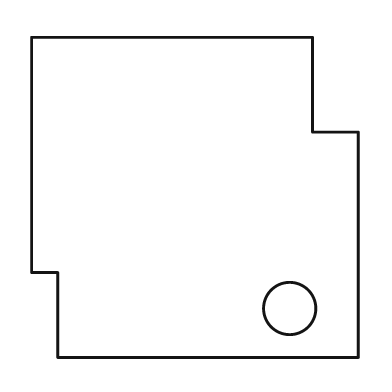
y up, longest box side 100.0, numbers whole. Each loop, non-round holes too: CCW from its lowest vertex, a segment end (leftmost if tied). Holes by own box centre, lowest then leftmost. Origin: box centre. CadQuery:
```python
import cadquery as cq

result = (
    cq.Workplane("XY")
    .moveTo(-42.0, -49.0)
    .lineTo(50.0, -49.0)
    .lineTo(50.0, 20.0)
    .lineTo(36.0, 20.0)
    .lineTo(36.0, 49.0)
    .lineTo(-50.0, 49.0)
    .lineTo(-50.0, -23.0)
    .lineTo(-42.0, -23.0)
    .close()
    .moveTo(29.0, -34.0)
    .circle(8.0)
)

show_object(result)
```